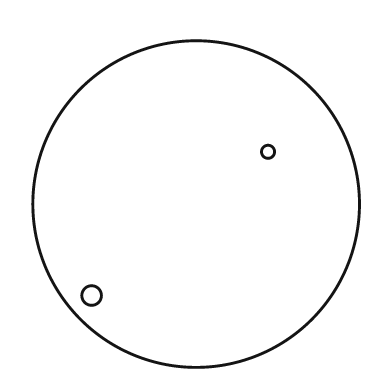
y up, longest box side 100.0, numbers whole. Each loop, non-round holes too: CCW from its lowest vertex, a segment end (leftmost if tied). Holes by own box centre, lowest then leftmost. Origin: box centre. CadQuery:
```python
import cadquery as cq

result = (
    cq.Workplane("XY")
    .moveTo(0.0, 0.0)
    .circle(50.0)
    .moveTo(-32.0, -28.0)
    .circle(3.0)
    .moveTo(22.0, 16.0)
    .circle(2.0)
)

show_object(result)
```